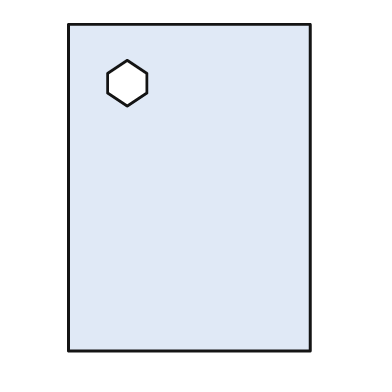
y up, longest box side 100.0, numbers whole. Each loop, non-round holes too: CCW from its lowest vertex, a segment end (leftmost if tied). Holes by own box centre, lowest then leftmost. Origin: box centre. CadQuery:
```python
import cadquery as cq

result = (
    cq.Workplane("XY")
    .moveTo(-37.0, -50.0)
    .lineTo(37.0, -50.0)
    .lineTo(37.0, 50.0)
    .lineTo(-37.0, 50.0)
    .close()
    .moveTo(-19.0, 25.0)
    .lineTo(-13.0, 29.0)
    .lineTo(-13.0, 35.0)
    .lineTo(-19.0, 39.0)
    .lineTo(-25.0, 35.0)
    .lineTo(-25.0, 29.0)
    .close()
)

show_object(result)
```